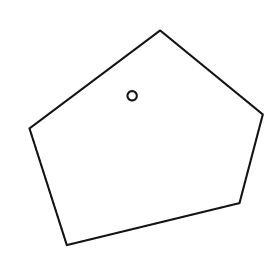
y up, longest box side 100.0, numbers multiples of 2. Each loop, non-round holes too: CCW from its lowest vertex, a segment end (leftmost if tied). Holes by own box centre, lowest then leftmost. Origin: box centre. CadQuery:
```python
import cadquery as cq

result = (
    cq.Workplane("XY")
    .moveTo(-34.0, -46.0)
    .lineTo(40.0, -28.0)
    .lineTo(50.0, 10.0)
    .lineTo(6.0, 46.0)
    .lineTo(-50.0, 4.0)
    .close()
    .moveTo(-6.0, 18.0)
    .circle(2.0)
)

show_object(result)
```